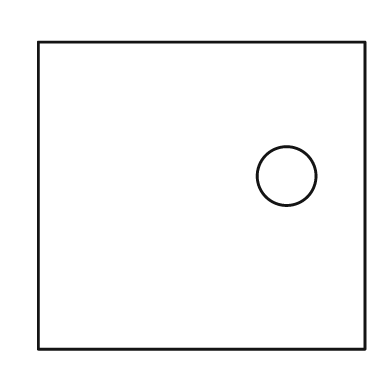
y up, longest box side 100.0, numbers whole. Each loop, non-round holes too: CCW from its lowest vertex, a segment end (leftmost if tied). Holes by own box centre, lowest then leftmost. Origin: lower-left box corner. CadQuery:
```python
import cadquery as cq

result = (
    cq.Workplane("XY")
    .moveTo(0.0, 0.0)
    .lineTo(100.0, 0.0)
    .lineTo(100.0, 94.0)
    .lineTo(0.0, 94.0)
    .close()
    .moveTo(76.0, 53.0)
    .circle(9.0)
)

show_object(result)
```